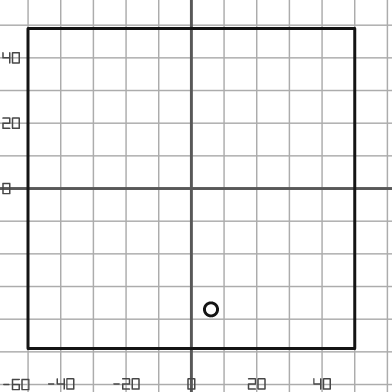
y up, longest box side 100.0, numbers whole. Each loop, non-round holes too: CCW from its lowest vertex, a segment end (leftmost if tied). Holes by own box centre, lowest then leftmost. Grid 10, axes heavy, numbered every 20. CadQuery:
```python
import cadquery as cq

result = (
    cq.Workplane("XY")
    .moveTo(-50.0, -49.0)
    .lineTo(50.0, -49.0)
    .lineTo(50.0, 49.0)
    .lineTo(-50.0, 49.0)
    .close()
    .moveTo(6.0, -37.0)
    .circle(2.0)
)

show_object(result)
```